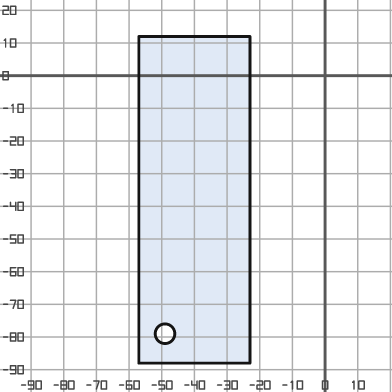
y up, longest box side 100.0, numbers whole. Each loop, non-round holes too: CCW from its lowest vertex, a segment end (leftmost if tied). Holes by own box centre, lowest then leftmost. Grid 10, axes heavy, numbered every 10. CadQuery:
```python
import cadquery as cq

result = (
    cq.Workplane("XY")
    .moveTo(-57.0, -88.0)
    .lineTo(-23.0, -88.0)
    .lineTo(-23.0, 12.0)
    .lineTo(-57.0, 12.0)
    .close()
    .moveTo(-49.0, -79.0)
    .circle(3.0)
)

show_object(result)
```